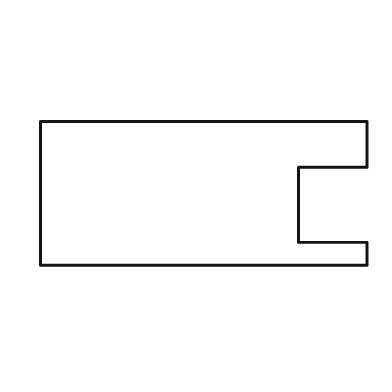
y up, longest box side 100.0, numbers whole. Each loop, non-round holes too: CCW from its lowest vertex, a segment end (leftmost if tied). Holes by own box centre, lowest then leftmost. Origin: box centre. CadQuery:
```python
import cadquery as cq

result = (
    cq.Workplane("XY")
    .moveTo(-50.0, -22.0)
    .lineTo(50.0, -22.0)
    .lineTo(50.0, -15.0)
    .lineTo(29.0, -15.0)
    .lineTo(29.0, 8.0)
    .lineTo(50.0, 8.0)
    .lineTo(50.0, 22.0)
    .lineTo(-50.0, 22.0)
    .close()
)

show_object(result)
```